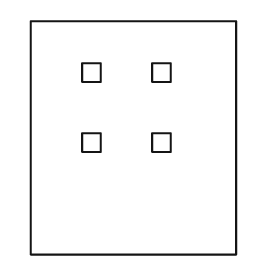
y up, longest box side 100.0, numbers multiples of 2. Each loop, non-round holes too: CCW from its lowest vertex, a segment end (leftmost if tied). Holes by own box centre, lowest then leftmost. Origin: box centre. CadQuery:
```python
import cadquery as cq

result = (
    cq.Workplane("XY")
    .moveTo(-44.0, -50.0)
    .lineTo(44.0, -50.0)
    .lineTo(44.0, 50.0)
    .lineTo(-44.0, 50.0)
    .close()
    .moveTo(-22.0, -6.0)
    .lineTo(-14.0, -6.0)
    .lineTo(-14.0, 2.0)
    .lineTo(-22.0, 2.0)
    .close()
    .moveTo(8.0, -6.0)
    .lineTo(16.0, -6.0)
    .lineTo(16.0, 2.0)
    .lineTo(8.0, 2.0)
    .close()
    .moveTo(-22.0, 24.0)
    .lineTo(-14.0, 24.0)
    .lineTo(-14.0, 32.0)
    .lineTo(-22.0, 32.0)
    .close()
    .moveTo(8.0, 24.0)
    .lineTo(16.0, 24.0)
    .lineTo(16.0, 32.0)
    .lineTo(8.0, 32.0)
    .close()
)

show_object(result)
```